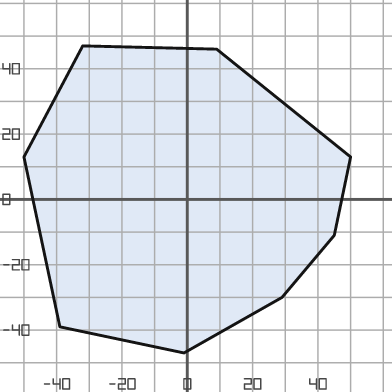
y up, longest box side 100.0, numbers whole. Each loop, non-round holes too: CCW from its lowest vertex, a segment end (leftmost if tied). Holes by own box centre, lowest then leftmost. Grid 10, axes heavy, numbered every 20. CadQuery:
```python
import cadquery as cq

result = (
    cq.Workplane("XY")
    .moveTo(-1.0, -47.0)
    .lineTo(29.0, -30.0)
    .lineTo(45.0, -11.0)
    .lineTo(50.0, 13.0)
    .lineTo(9.0, 46.0)
    .lineTo(-32.0, 47.0)
    .lineTo(-50.0, 13.0)
    .lineTo(-39.0, -39.0)
    .close()
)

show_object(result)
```